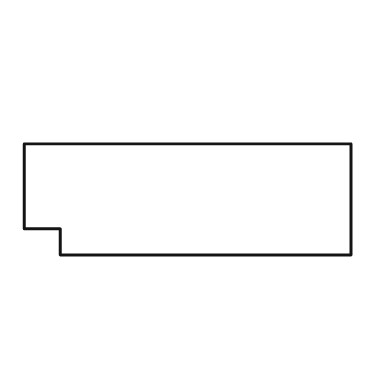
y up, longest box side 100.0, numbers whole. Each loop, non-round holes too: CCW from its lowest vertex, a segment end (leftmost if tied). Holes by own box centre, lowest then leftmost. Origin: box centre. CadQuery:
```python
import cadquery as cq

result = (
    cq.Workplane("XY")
    .moveTo(-39.0, -17.0)
    .lineTo(50.0, -17.0)
    .lineTo(50.0, 17.0)
    .lineTo(-50.0, 17.0)
    .lineTo(-50.0, -9.0)
    .lineTo(-39.0, -9.0)
    .close()
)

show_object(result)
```